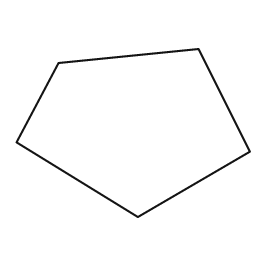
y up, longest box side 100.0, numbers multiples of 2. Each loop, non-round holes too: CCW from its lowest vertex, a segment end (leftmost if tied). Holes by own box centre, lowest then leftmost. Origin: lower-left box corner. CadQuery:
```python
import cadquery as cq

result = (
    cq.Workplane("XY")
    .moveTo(52.0, 0.0)
    .lineTo(100.0, 28.0)
    .lineTo(78.0, 72.0)
    .lineTo(18.0, 66.0)
    .lineTo(0.0, 32.0)
    .close()
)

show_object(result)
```